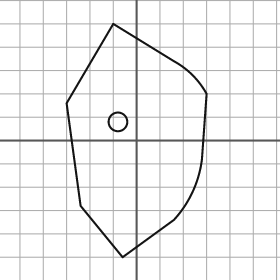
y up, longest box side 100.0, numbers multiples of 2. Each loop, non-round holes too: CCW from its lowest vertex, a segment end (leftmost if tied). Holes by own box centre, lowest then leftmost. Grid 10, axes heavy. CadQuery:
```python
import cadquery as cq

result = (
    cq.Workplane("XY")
    .moveTo(-6.0, -50.0)
    .lineTo(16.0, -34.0)
    .threePointArc((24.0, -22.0), (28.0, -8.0))
    .lineTo(30.0, 20.0)
    .threePointArc((24.0, 28.0), (16.0, 34.0))
    .lineTo(-10.0, 50.0)
    .lineTo(-30.0, 16.0)
    .lineTo(-24.0, -28.0)
    .close()
    .moveTo(-8.0, 8.0)
    .circle(4.0)
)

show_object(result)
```